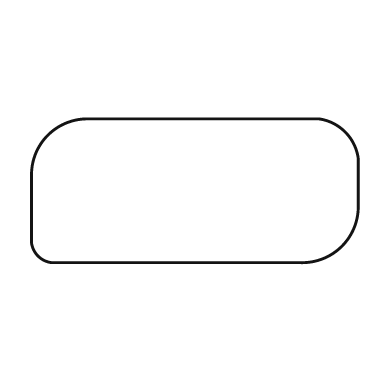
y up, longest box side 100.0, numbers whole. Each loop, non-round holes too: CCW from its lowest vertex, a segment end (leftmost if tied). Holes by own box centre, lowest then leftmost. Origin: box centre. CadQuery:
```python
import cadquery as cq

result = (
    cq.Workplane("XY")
    .moveTo(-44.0, -22.0)
    .lineTo(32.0, -22.0)
    .threePointArc((45.0, -17.0), (50.0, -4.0))
    .lineTo(50.0, 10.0)
    .threePointArc((46.0, 18.0), (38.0, 22.0))
    .lineTo(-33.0, 22.0)
    .threePointArc((-45.0, 17.0), (-50.0, 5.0))
    .lineTo(-50.0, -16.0)
    .threePointArc((-48.0, -20.0), (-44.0, -22.0))
    .close()
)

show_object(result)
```